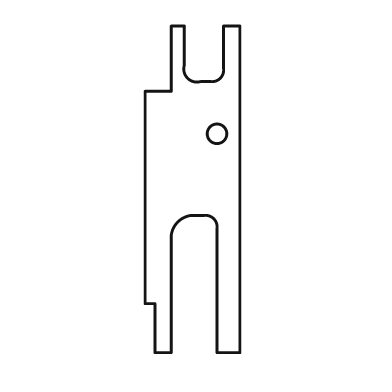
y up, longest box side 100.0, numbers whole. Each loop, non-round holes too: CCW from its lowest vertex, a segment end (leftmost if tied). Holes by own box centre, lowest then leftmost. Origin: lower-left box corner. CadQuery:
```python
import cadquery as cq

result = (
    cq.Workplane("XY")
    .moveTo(3.0, 0.0)
    .lineTo(8.0, 0.0)
    .lineTo(8.0, 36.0)
    .threePointArc((10.0, 40.0), (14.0, 42.0))
    .lineTo(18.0, 42.0)
    .threePointArc((21.0, 41.0), (22.0, 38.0))
    .lineTo(22.0, 0.0)
    .lineTo(29.0, 0.0)
    .lineTo(29.0, 100.0)
    .lineTo(24.0, 100.0)
    .lineTo(24.0, 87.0)
    .threePointArc((23.0, 84.0), (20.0, 83.0))
    .lineTo(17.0, 83.0)
    .threePointArc((13.0, 84.0), (12.0, 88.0))
    .lineTo(12.0, 100.0)
    .lineTo(8.0, 100.0)
    .lineTo(8.0, 80.0)
    .lineTo(0.0, 80.0)
    .lineTo(0.0, 15.0)
    .lineTo(3.0, 15.0)
    .close()
    .moveTo(22.0, 67.0)
    .circle(3.0)
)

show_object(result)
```